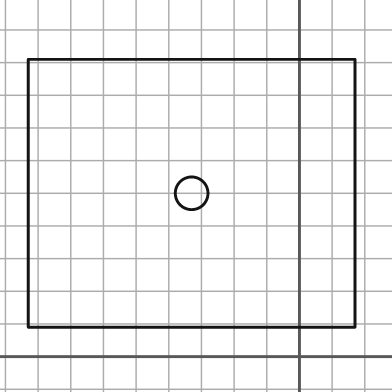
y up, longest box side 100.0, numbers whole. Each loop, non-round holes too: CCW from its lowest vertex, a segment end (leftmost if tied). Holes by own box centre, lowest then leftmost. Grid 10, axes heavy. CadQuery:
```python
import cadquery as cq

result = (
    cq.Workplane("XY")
    .moveTo(-83.0, 9.0)
    .lineTo(17.0, 9.0)
    .lineTo(17.0, 91.0)
    .lineTo(-83.0, 91.0)
    .close()
    .moveTo(-33.0, 50.0)
    .circle(5.0)
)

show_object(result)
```